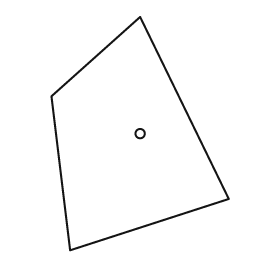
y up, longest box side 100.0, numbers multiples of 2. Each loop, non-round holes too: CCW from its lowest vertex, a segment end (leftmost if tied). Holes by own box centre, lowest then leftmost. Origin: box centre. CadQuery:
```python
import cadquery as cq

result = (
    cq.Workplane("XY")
    .moveTo(-30.0, -50.0)
    .lineTo(38.0, -28.0)
    .lineTo(0.0, 50.0)
    .lineTo(-38.0, 16.0)
    .close()
    .moveTo(0.0, 0.0)
    .circle(2.0)
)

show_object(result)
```